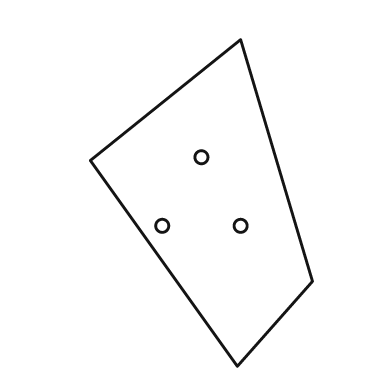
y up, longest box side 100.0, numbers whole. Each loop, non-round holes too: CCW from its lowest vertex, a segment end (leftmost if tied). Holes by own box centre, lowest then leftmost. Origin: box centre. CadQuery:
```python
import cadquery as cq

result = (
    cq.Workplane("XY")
    .moveTo(11.0, -50.0)
    .lineTo(34.0, -24.0)
    .lineTo(12.0, 50.0)
    .lineTo(-34.0, 13.0)
    .close()
    .moveTo(-12.0, -7.0)
    .circle(2.0)
    .moveTo(12.0, -7.0)
    .circle(2.0)
    .moveTo(0.0, 14.0)
    .circle(2.0)
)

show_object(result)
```